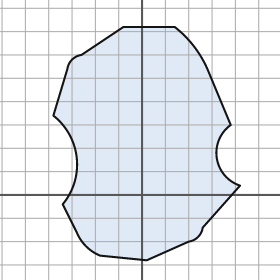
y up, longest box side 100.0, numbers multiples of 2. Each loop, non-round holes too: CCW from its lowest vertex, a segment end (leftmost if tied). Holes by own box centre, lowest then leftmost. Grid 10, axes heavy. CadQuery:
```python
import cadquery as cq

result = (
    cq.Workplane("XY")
    .moveTo(2.0, -28.0)
    .lineTo(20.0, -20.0)
    .threePointArc((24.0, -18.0), (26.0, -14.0))
    .lineTo(42.0, 4.0)
    .threePointArc((32.0, 16.0), (38.0, 30.0))
    .lineTo(28.0, 54.0)
    .threePointArc((22.0, 64.0), (14.0, 72.0))
    .lineTo(-8.0, 72.0)
    .lineTo(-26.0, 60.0)
    .threePointArc((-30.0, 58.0), (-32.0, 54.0))
    .lineTo(-38.0, 34.0)
    .threePointArc((-28.0, 16.0), (-34.0, -4.0))
    .lineTo(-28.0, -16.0)
    .threePointArc((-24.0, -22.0), (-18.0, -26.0))
    .close()
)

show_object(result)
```